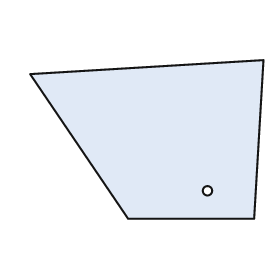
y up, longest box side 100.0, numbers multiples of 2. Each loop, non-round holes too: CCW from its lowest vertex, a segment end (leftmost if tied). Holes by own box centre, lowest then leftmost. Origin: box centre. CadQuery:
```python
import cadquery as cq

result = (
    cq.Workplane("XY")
    .moveTo(-8.0, -34.0)
    .lineTo(46.0, -34.0)
    .lineTo(50.0, 34.0)
    .lineTo(-50.0, 28.0)
    .close()
    .moveTo(26.0, -22.0)
    .circle(2.0)
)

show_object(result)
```